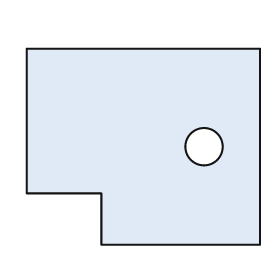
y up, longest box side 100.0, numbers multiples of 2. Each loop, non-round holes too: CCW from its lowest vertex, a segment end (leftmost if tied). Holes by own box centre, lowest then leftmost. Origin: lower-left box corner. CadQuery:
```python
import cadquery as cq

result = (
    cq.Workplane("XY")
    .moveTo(32.0, 0.0)
    .lineTo(100.0, 0.0)
    .lineTo(100.0, 84.0)
    .lineTo(0.0, 84.0)
    .lineTo(0.0, 22.0)
    .lineTo(32.0, 22.0)
    .close()
    .moveTo(76.0, 42.0)
    .circle(8.0)
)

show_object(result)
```